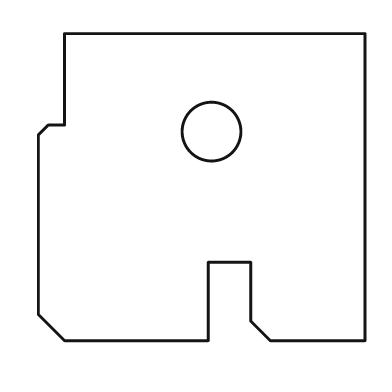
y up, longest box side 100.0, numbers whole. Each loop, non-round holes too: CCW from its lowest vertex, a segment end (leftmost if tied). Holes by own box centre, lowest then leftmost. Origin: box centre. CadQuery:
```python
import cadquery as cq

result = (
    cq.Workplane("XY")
    .moveTo(-42.0, -47.0)
    .lineTo(2.0, -47.0)
    .lineTo(2.0, -23.0)
    .lineTo(15.0, -23.0)
    .lineTo(15.0, -41.0)
    .lineTo(21.0, -47.0)
    .lineTo(50.0, -47.0)
    .lineTo(50.0, 47.0)
    .lineTo(-42.0, 47.0)
    .lineTo(-42.0, 19.0)
    .lineTo(-47.0, 19.0)
    .lineTo(-50.0, 16.0)
    .lineTo(-50.0, -39.0)
    .close()
    .moveTo(3.0, 17.0)
    .circle(9.0)
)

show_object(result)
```